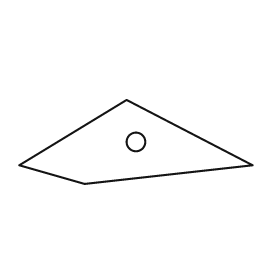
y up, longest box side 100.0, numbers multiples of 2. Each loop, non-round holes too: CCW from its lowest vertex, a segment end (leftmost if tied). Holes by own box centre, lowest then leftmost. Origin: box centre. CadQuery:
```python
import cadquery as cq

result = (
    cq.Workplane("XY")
    .moveTo(-22.0, -18.0)
    .lineTo(50.0, -10.0)
    .lineTo(-4.0, 18.0)
    .lineTo(-50.0, -10.0)
    .close()
    .moveTo(0.0, 0.0)
    .circle(4.0)
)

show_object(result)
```